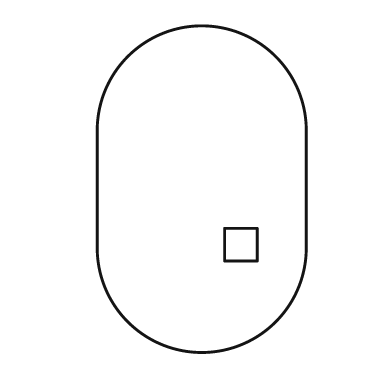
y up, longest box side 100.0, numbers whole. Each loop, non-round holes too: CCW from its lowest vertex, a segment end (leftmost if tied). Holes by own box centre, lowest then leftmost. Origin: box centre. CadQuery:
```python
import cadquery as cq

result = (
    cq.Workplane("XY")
    .moveTo(-32.0, -18.0)
    .threePointArc((0.0, -50.0), (32.0, -18.0))
    .lineTo(32.0, 18.0)
    .threePointArc((0.0, 50.0), (-32.0, 18.0))
    .close()
    .moveTo(7.0, -22.0)
    .lineTo(17.0, -22.0)
    .lineTo(17.0, -12.0)
    .lineTo(7.0, -12.0)
    .close()
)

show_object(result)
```